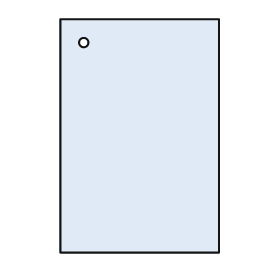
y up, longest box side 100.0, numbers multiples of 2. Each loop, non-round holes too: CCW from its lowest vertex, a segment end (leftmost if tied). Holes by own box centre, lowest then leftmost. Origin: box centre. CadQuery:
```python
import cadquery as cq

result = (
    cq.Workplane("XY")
    .moveTo(-34.0, -50.0)
    .lineTo(34.0, -50.0)
    .lineTo(34.0, 50.0)
    .lineTo(-34.0, 50.0)
    .close()
    .moveTo(-24.0, 40.0)
    .circle(2.0)
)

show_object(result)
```